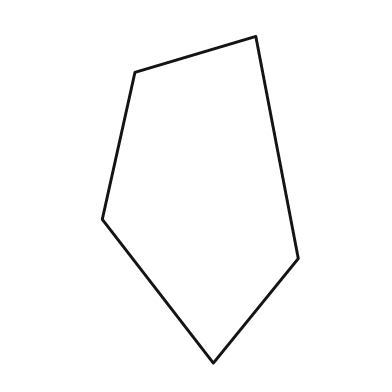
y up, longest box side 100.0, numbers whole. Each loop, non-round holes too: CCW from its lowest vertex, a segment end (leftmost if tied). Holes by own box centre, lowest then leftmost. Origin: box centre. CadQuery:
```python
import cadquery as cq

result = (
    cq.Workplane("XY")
    .moveTo(4.0, -50.0)
    .lineTo(30.0, -18.0)
    .lineTo(17.0, 50.0)
    .lineTo(-20.0, 39.0)
    .lineTo(-30.0, -6.0)
    .close()
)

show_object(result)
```